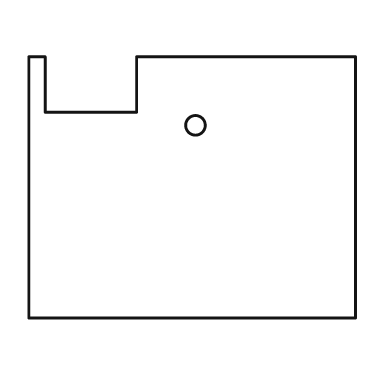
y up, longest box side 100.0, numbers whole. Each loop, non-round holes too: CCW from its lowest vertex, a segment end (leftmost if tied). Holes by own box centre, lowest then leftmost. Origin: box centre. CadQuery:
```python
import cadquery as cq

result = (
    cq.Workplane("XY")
    .moveTo(-50.0, -40.0)
    .lineTo(50.0, -40.0)
    .lineTo(50.0, 40.0)
    .lineTo(-17.0, 40.0)
    .lineTo(-17.0, 23.0)
    .lineTo(-45.0, 23.0)
    .lineTo(-45.0, 40.0)
    .lineTo(-50.0, 40.0)
    .close()
    .moveTo(1.0, 19.0)
    .circle(3.0)
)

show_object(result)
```